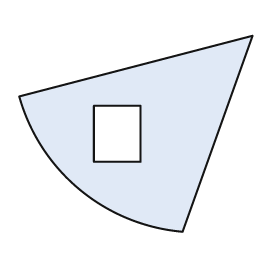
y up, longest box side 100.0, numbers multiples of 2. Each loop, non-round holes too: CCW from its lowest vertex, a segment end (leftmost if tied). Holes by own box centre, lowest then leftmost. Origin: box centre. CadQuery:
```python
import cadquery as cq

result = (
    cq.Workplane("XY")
    .moveTo(20.0, -42.0)
    .lineTo(50.0, 42.0)
    .lineTo(-50.0, 16.0)
    .threePointArc((-24.0, -24.0), (20.0, -42.0))
    .close()
    .moveTo(-18.0, -12.0)
    .lineTo(2.0, -12.0)
    .lineTo(2.0, 12.0)
    .lineTo(-18.0, 12.0)
    .close()
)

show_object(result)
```